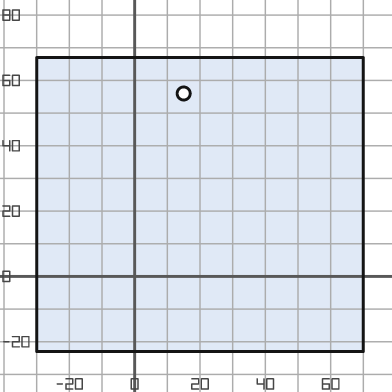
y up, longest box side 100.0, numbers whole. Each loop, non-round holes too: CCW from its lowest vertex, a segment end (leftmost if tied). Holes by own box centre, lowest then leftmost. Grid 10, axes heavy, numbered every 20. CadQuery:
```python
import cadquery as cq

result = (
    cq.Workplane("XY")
    .moveTo(-30.0, -23.0)
    .lineTo(70.0, -23.0)
    .lineTo(70.0, 67.0)
    .lineTo(-30.0, 67.0)
    .close()
    .moveTo(15.0, 56.0)
    .circle(2.0)
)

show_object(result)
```